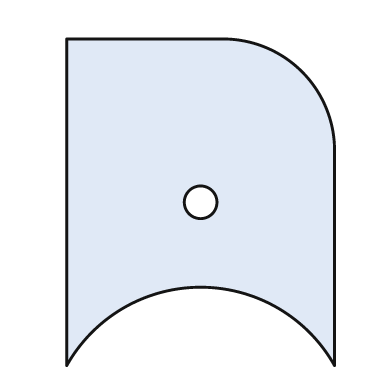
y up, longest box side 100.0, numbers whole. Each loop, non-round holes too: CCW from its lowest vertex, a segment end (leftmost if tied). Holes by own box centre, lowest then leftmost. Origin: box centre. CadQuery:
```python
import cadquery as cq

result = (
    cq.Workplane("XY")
    .moveTo(-41.0, -50.0)
    .threePointArc((0.0, -26.0), (41.0, -50.0))
    .lineTo(41.0, 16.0)
    .threePointArc((31.0, 40.0), (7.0, 50.0))
    .lineTo(-41.0, 50.0)
    .close()
    .moveTo(0.0, 0.0)
    .circle(5.0)
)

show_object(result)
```